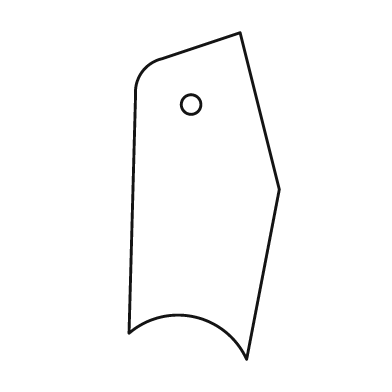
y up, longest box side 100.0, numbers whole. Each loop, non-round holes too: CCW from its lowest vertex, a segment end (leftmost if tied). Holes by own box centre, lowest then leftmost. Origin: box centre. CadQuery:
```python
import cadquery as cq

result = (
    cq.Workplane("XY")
    .moveTo(13.0, -50.0)
    .lineTo(23.0, 2.0)
    .lineTo(11.0, 50.0)
    .lineTo(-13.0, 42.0)
    .threePointArc((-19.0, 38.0), (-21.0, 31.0))
    .lineTo(-23.0, -42.0)
    .threePointArc((-3.0, -37.0), (13.0, -50.0))
    .close()
    .moveTo(-4.0, 28.0)
    .circle(3.0)
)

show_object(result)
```